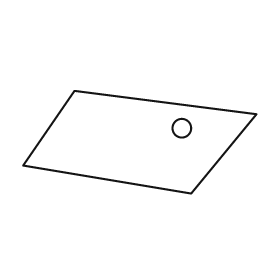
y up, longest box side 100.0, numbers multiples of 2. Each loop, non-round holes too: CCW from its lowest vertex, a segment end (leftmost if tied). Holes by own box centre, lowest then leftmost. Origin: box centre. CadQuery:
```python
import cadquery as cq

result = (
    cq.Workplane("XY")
    .moveTo(22.0, -22.0)
    .lineTo(50.0, 12.0)
    .lineTo(-28.0, 22.0)
    .lineTo(-50.0, -10.0)
    .close()
    .moveTo(18.0, 6.0)
    .circle(4.0)
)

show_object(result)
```